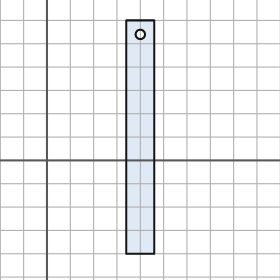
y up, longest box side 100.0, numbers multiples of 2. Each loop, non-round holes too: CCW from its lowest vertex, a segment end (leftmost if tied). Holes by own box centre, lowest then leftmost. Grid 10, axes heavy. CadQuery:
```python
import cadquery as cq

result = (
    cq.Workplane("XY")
    .moveTo(34.0, -40.0)
    .lineTo(46.0, -40.0)
    .lineTo(46.0, 60.0)
    .lineTo(34.0, 60.0)
    .close()
    .moveTo(40.0, 54.0)
    .circle(2.0)
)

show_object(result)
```